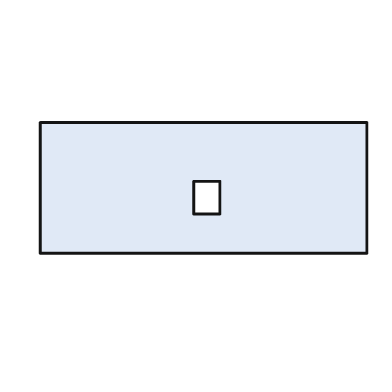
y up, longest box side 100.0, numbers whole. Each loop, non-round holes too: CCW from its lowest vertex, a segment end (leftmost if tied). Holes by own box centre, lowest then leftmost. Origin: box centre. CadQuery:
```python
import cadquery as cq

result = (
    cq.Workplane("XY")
    .moveTo(-50.0, -20.0)
    .lineTo(50.0, -20.0)
    .lineTo(50.0, 20.0)
    .lineTo(-50.0, 20.0)
    .close()
    .moveTo(-3.0, -8.0)
    .lineTo(5.0, -8.0)
    .lineTo(5.0, 2.0)
    .lineTo(-3.0, 2.0)
    .close()
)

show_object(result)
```